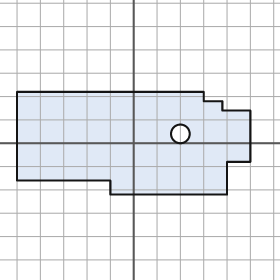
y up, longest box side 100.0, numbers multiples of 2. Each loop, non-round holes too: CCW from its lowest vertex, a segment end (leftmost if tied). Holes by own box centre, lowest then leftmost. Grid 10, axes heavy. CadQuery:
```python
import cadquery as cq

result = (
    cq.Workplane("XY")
    .moveTo(-10.0, -22.0)
    .lineTo(40.0, -22.0)
    .lineTo(40.0, -8.0)
    .lineTo(50.0, -8.0)
    .lineTo(50.0, 14.0)
    .lineTo(38.0, 14.0)
    .lineTo(38.0, 18.0)
    .lineTo(30.0, 18.0)
    .lineTo(30.0, 22.0)
    .lineTo(-50.0, 22.0)
    .lineTo(-50.0, -16.0)
    .lineTo(-10.0, -16.0)
    .close()
    .moveTo(20.0, 4.0)
    .circle(4.0)
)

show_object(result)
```